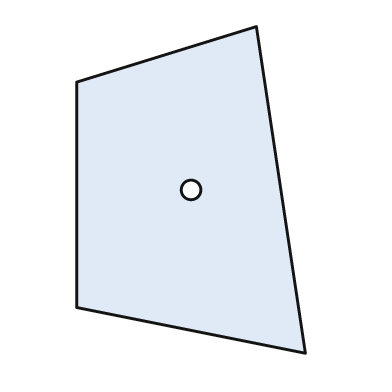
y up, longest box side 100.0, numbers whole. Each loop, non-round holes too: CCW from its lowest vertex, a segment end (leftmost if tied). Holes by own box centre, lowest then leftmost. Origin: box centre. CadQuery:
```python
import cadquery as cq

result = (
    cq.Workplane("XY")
    .moveTo(35.0, -50.0)
    .lineTo(20.0, 50.0)
    .lineTo(-35.0, 33.0)
    .lineTo(-35.0, -36.0)
    .close()
    .moveTo(0.0, 0.0)
    .circle(3.0)
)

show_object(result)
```